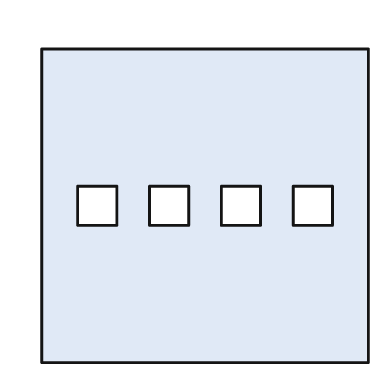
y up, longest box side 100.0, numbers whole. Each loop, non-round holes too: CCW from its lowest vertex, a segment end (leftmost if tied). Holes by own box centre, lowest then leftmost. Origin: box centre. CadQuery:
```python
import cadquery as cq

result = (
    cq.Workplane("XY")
    .moveTo(-50.0, -48.0)
    .lineTo(50.0, -48.0)
    .lineTo(50.0, 48.0)
    .lineTo(-50.0, 48.0)
    .close()
    .moveTo(-39.0, -6.0)
    .lineTo(-27.0, -6.0)
    .lineTo(-27.0, 6.0)
    .lineTo(-39.0, 6.0)
    .close()
    .moveTo(-17.0, -6.0)
    .lineTo(-5.0, -6.0)
    .lineTo(-5.0, 6.0)
    .lineTo(-17.0, 6.0)
    .close()
    .moveTo(5.0, -6.0)
    .lineTo(17.0, -6.0)
    .lineTo(17.0, 6.0)
    .lineTo(5.0, 6.0)
    .close()
    .moveTo(27.0, -6.0)
    .lineTo(39.0, -6.0)
    .lineTo(39.0, 6.0)
    .lineTo(27.0, 6.0)
    .close()
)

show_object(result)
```